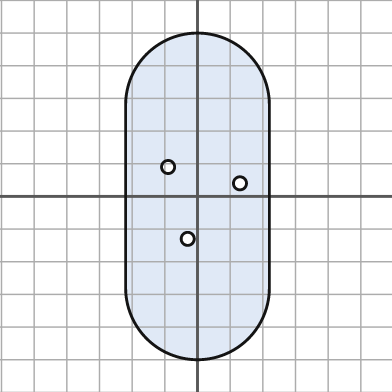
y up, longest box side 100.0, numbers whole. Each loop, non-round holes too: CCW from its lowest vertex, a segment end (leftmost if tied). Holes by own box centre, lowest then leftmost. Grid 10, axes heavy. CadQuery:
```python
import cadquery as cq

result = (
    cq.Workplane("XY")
    .moveTo(-22.0, -28.0)
    .threePointArc((0.0, -50.0), (22.0, -28.0))
    .lineTo(22.0, 28.0)
    .threePointArc((0.0, 50.0), (-22.0, 28.0))
    .close()
    .moveTo(-3.0, -13.0)
    .circle(2.0)
    .moveTo(13.0, 4.0)
    .circle(2.0)
    .moveTo(-9.0, 9.0)
    .circle(2.0)
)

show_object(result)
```